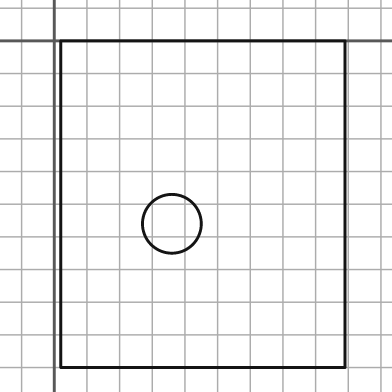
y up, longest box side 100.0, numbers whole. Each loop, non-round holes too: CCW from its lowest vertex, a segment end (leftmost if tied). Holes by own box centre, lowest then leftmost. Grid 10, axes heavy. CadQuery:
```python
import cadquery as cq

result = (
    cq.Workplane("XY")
    .moveTo(2.0, -100.0)
    .lineTo(89.0, -100.0)
    .lineTo(89.0, 0.0)
    .lineTo(2.0, 0.0)
    .close()
    .moveTo(36.0, -56.0)
    .circle(9.0)
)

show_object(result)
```